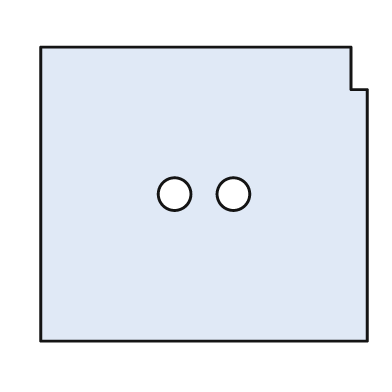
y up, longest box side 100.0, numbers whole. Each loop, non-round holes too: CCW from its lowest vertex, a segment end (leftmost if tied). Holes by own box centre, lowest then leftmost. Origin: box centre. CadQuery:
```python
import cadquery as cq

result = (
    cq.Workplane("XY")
    .moveTo(-50.0, -45.0)
    .lineTo(50.0, -45.0)
    .lineTo(50.0, 32.0)
    .lineTo(45.0, 32.0)
    .lineTo(45.0, 45.0)
    .lineTo(-50.0, 45.0)
    .close()
    .moveTo(-9.0, 0.0)
    .circle(5.0)
    .moveTo(9.0, 0.0)
    .circle(5.0)
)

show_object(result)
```